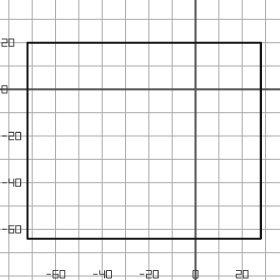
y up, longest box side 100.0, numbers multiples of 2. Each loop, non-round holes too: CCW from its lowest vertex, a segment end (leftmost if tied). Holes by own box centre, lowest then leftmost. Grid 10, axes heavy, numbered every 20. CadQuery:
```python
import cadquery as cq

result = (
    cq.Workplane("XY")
    .moveTo(-72.0, -64.0)
    .lineTo(28.0, -64.0)
    .lineTo(28.0, 20.0)
    .lineTo(-72.0, 20.0)
    .close()
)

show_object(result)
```